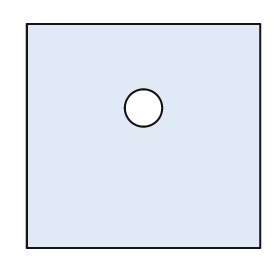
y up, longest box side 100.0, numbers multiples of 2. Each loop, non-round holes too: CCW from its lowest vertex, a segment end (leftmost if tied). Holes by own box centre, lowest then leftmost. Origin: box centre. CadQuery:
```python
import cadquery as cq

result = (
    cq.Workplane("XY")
    .moveTo(-50.0, -48.0)
    .lineTo(50.0, -48.0)
    .lineTo(50.0, 48.0)
    .lineTo(-50.0, 48.0)
    .close()
    .moveTo(0.0, 12.0)
    .circle(8.0)
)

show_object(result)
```